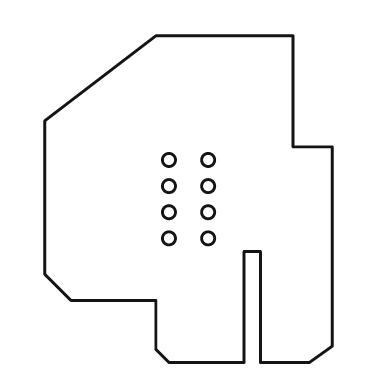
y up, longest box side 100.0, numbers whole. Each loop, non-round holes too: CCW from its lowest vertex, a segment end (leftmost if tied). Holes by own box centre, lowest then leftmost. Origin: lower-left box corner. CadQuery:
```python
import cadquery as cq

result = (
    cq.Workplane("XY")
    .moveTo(38.0, 0.0)
    .lineTo(61.0, 0.0)
    .lineTo(61.0, 34.0)
    .lineTo(66.0, 34.0)
    .lineTo(66.0, 0.0)
    .lineTo(81.0, 0.0)
    .lineTo(88.0, 5.0)
    .lineTo(88.0, 66.0)
    .lineTo(76.0, 66.0)
    .lineTo(76.0, 100.0)
    .lineTo(34.0, 100.0)
    .lineTo(0.0, 74.0)
    .lineTo(0.0, 27.0)
    .lineTo(8.0, 19.0)
    .lineTo(34.0, 19.0)
    .lineTo(34.0, 4.0)
    .close()
    .moveTo(38.0, 38.0)
    .circle(2.0)
    .moveTo(50.0, 38.0)
    .circle(2.0)
    .moveTo(38.0, 46.0)
    .circle(2.0)
    .moveTo(50.0, 46.0)
    .circle(2.0)
    .moveTo(38.0, 54.0)
    .circle(2.0)
    .moveTo(50.0, 54.0)
    .circle(2.0)
    .moveTo(38.0, 62.0)
    .circle(2.0)
    .moveTo(50.0, 62.0)
    .circle(2.0)
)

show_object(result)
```